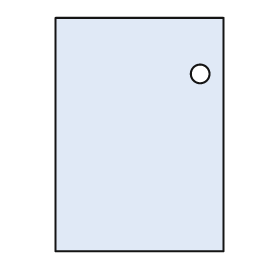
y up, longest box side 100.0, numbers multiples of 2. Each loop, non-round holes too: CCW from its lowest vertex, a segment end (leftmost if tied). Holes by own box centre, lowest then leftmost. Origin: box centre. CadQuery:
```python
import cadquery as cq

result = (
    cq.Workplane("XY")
    .moveTo(-36.0, -50.0)
    .lineTo(36.0, -50.0)
    .lineTo(36.0, 50.0)
    .lineTo(-36.0, 50.0)
    .close()
    .moveTo(26.0, 26.0)
    .circle(4.0)
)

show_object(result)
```